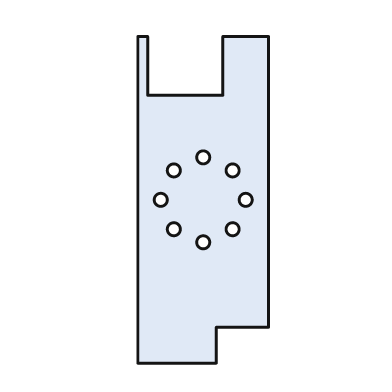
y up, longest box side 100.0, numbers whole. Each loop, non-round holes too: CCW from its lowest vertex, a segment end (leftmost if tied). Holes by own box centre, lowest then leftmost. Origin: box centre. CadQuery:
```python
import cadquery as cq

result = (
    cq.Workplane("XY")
    .moveTo(-20.0, -50.0)
    .lineTo(4.0, -50.0)
    .lineTo(4.0, -39.0)
    .lineTo(20.0, -39.0)
    .lineTo(20.0, 50.0)
    .lineTo(6.0, 50.0)
    .lineTo(6.0, 32.0)
    .lineTo(-17.0, 32.0)
    .lineTo(-17.0, 50.0)
    .lineTo(-20.0, 50.0)
    .close()
    .moveTo(0.0, -13.0)
    .circle(2.0)
    .moveTo(-9.0, -9.0)
    .circle(2.0)
    .moveTo(9.0, -9.0)
    .circle(2.0)
    .moveTo(-13.0, 0.0)
    .circle(2.0)
    .moveTo(13.0, 0.0)
    .circle(2.0)
    .moveTo(-9.0, 9.0)
    .circle(2.0)
    .moveTo(9.0, 9.0)
    .circle(2.0)
    .moveTo(0.0, 13.0)
    .circle(2.0)
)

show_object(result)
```